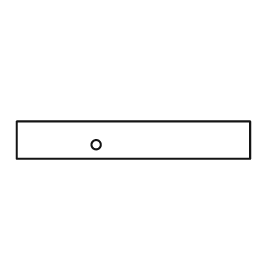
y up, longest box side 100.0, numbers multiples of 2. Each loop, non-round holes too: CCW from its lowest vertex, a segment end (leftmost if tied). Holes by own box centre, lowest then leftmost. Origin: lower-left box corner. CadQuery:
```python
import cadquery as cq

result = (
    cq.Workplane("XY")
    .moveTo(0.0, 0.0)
    .lineTo(100.0, 0.0)
    .lineTo(100.0, 16.0)
    .lineTo(0.0, 16.0)
    .close()
    .moveTo(34.0, 6.0)
    .circle(2.0)
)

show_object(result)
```